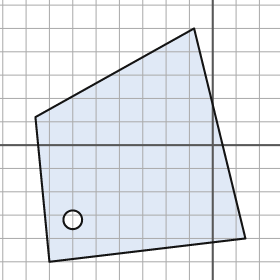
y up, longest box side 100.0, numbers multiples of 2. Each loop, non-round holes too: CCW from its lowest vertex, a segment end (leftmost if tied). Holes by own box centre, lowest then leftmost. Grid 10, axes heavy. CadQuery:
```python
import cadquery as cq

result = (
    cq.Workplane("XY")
    .moveTo(-70.0, -50.0)
    .lineTo(14.0, -40.0)
    .lineTo(-8.0, 50.0)
    .lineTo(-76.0, 12.0)
    .close()
    .moveTo(-60.0, -32.0)
    .circle(4.0)
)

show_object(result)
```